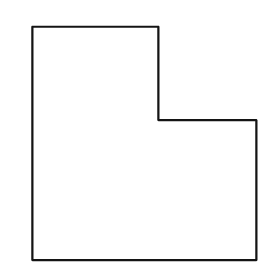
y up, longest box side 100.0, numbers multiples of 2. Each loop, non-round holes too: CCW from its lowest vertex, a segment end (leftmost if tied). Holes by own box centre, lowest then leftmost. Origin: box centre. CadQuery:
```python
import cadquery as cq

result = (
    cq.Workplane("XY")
    .moveTo(-48.0, -50.0)
    .lineTo(48.0, -50.0)
    .lineTo(48.0, 10.0)
    .lineTo(6.0, 10.0)
    .lineTo(6.0, 50.0)
    .lineTo(-48.0, 50.0)
    .close()
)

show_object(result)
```